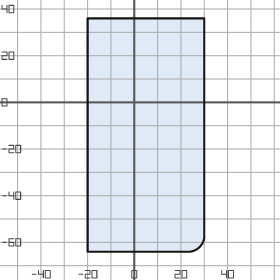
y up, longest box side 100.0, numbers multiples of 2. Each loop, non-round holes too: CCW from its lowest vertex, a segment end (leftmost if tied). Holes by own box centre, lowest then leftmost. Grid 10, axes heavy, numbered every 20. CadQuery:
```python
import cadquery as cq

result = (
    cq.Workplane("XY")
    .moveTo(-20.0, -64.0)
    .lineTo(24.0, -64.0)
    .threePointArc((28.0, -62.0), (30.0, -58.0))
    .lineTo(30.0, 36.0)
    .lineTo(-20.0, 36.0)
    .close()
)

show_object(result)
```